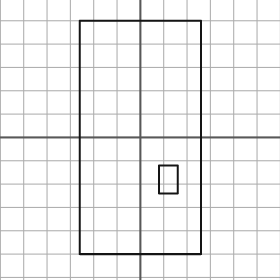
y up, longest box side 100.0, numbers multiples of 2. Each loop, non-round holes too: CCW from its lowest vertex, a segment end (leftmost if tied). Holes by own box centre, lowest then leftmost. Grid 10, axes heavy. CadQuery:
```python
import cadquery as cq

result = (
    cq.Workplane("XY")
    .moveTo(-26.0, -50.0)
    .lineTo(26.0, -50.0)
    .lineTo(26.0, 50.0)
    .lineTo(-26.0, 50.0)
    .close()
    .moveTo(8.0, -24.0)
    .lineTo(16.0, -24.0)
    .lineTo(16.0, -12.0)
    .lineTo(8.0, -12.0)
    .close()
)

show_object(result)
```